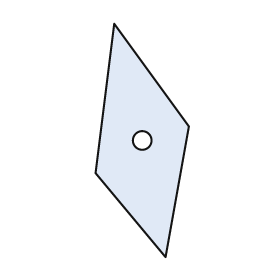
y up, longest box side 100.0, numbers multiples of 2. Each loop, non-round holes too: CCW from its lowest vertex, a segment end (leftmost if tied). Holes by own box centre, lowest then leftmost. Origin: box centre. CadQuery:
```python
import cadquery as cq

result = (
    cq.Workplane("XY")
    .moveTo(10.0, -50.0)
    .lineTo(20.0, 6.0)
    .lineTo(-12.0, 50.0)
    .lineTo(-20.0, -14.0)
    .close()
    .moveTo(0.0, 0.0)
    .circle(4.0)
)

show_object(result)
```